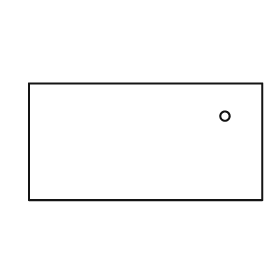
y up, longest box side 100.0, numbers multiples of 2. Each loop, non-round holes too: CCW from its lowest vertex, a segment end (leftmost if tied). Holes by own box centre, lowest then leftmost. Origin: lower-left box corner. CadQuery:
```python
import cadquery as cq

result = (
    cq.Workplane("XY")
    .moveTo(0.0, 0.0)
    .lineTo(100.0, 0.0)
    .lineTo(100.0, 50.0)
    .lineTo(0.0, 50.0)
    .close()
    .moveTo(84.0, 36.0)
    .circle(2.0)
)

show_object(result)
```